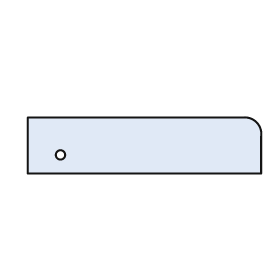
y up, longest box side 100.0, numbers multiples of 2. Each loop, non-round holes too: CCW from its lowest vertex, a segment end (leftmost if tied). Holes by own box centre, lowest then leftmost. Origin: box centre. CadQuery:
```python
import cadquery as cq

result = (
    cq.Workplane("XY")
    .moveTo(-50.0, -12.0)
    .lineTo(50.0, -12.0)
    .lineTo(50.0, 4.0)
    .threePointArc((48.0, 10.0), (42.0, 12.0))
    .lineTo(-50.0, 12.0)
    .close()
    .moveTo(-36.0, -4.0)
    .circle(2.0)
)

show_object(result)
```